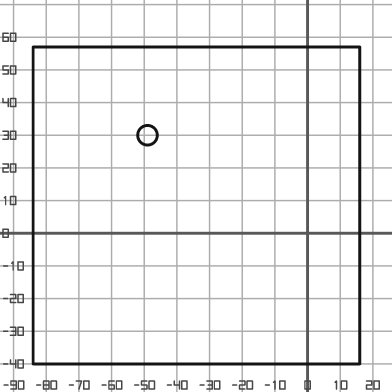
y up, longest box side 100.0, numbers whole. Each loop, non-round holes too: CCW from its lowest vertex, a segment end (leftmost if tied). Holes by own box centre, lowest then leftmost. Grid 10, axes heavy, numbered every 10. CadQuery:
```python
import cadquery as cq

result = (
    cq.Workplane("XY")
    .moveTo(-84.0, -40.0)
    .lineTo(16.0, -40.0)
    .lineTo(16.0, 57.0)
    .lineTo(-84.0, 57.0)
    .close()
    .moveTo(-49.0, 30.0)
    .circle(3.0)
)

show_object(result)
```